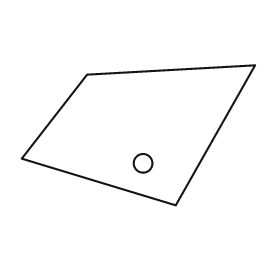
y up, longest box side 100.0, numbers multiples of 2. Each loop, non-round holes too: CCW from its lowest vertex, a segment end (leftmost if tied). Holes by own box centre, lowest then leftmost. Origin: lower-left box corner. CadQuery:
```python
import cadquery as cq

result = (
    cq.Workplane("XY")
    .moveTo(66.0, 0.0)
    .lineTo(100.0, 60.0)
    .lineTo(28.0, 56.0)
    .lineTo(0.0, 20.0)
    .close()
    .moveTo(52.0, 18.0)
    .circle(4.0)
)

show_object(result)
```